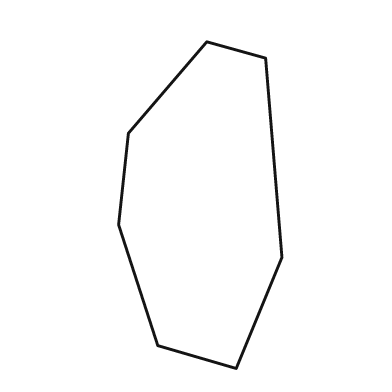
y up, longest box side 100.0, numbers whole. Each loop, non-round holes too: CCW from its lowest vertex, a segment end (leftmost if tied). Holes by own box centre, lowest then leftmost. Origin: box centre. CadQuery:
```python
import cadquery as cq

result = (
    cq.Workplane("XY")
    .moveTo(11.0, -50.0)
    .lineTo(25.0, -16.0)
    .lineTo(20.0, 45.0)
    .lineTo(2.0, 50.0)
    .lineTo(-22.0, 22.0)
    .lineTo(-25.0, -6.0)
    .lineTo(-13.0, -43.0)
    .close()
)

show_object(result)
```